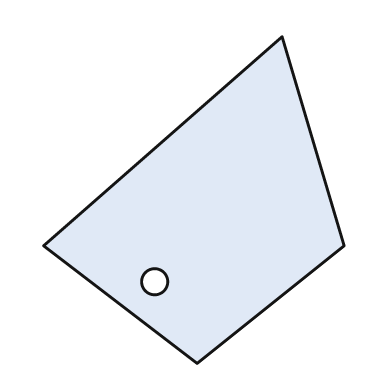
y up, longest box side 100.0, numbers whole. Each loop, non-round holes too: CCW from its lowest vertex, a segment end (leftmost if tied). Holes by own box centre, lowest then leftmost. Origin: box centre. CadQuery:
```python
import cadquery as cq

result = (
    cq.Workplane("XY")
    .moveTo(1.0, -50.0)
    .lineTo(46.0, -14.0)
    .lineTo(27.0, 50.0)
    .lineTo(-46.0, -14.0)
    .close()
    .moveTo(-12.0, -25.0)
    .circle(4.0)
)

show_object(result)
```